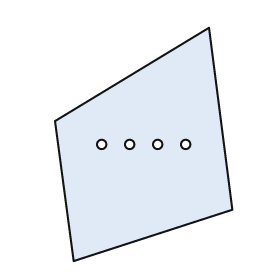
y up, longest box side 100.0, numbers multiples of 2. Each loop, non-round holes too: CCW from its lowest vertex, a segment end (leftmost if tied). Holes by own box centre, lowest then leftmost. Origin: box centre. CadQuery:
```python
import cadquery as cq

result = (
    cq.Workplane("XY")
    .moveTo(-30.0, -50.0)
    .lineTo(38.0, -28.0)
    .lineTo(28.0, 50.0)
    .lineTo(-38.0, 10.0)
    .close()
    .moveTo(-18.0, 0.0)
    .circle(2.0)
    .moveTo(-6.0, 0.0)
    .circle(2.0)
    .moveTo(6.0, 0.0)
    .circle(2.0)
    .moveTo(18.0, 0.0)
    .circle(2.0)
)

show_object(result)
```